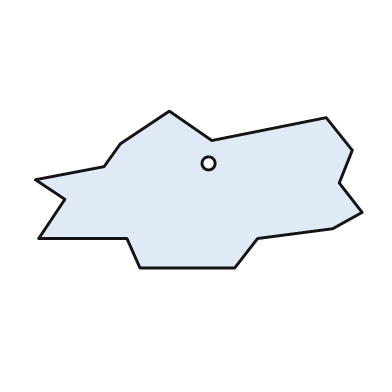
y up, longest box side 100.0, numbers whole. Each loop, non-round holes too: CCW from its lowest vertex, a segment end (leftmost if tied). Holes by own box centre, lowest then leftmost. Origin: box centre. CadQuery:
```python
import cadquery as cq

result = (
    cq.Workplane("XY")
    .moveTo(-18.0, -24.0)
    .lineTo(11.0, -24.0)
    .lineTo(18.0, -15.0)
    .lineTo(41.0, -12.0)
    .lineTo(50.0, -7.0)
    .lineTo(43.0, 2.0)
    .lineTo(47.0, 12.0)
    .lineTo(39.0, 22.0)
    .lineTo(4.0, 15.0)
    .lineTo(-9.0, 24.0)
    .lineTo(-24.0, 14.0)
    .lineTo(-29.0, 7.0)
    .lineTo(-50.0, 3.0)
    .lineTo(-41.0, -3.0)
    .lineTo(-49.0, -15.0)
    .lineTo(-22.0, -15.0)
    .close()
    .moveTo(3.0, 8.0)
    .circle(2.0)
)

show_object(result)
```